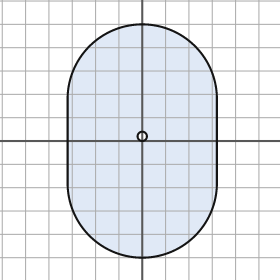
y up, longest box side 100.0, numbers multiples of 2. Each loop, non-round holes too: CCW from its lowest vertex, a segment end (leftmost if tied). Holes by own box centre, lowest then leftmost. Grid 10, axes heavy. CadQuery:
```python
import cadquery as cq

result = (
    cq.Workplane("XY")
    .moveTo(-32.0, -18.0)
    .threePointArc((0.0, -50.0), (32.0, -18.0))
    .lineTo(32.0, 18.0)
    .threePointArc((0.0, 50.0), (-32.0, 18.0))
    .close()
    .moveTo(0.0, 2.0)
    .circle(2.0)
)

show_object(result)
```